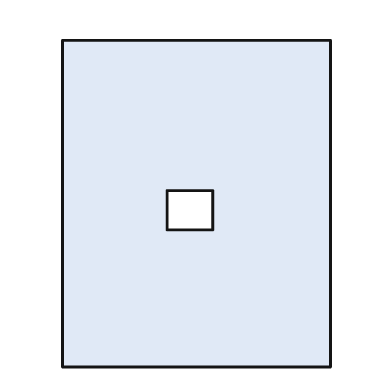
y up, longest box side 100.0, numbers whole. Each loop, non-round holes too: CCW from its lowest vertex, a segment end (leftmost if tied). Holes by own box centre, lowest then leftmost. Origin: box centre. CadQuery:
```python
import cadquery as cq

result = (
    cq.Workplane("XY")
    .moveTo(-41.0, -50.0)
    .lineTo(41.0, -50.0)
    .lineTo(41.0, 50.0)
    .lineTo(-41.0, 50.0)
    .close()
    .moveTo(-9.0, -8.0)
    .lineTo(5.0, -8.0)
    .lineTo(5.0, 4.0)
    .lineTo(-9.0, 4.0)
    .close()
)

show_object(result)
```